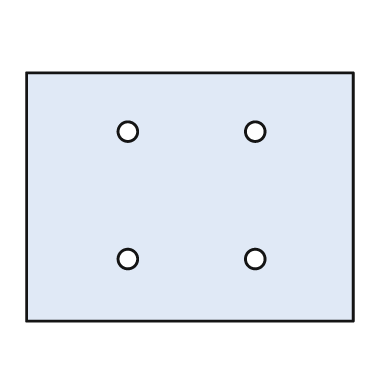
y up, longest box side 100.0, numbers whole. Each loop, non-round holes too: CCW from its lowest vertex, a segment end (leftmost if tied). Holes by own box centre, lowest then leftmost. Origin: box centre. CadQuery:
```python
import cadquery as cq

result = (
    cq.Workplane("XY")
    .moveTo(-50.0, -38.0)
    .lineTo(50.0, -38.0)
    .lineTo(50.0, 38.0)
    .lineTo(-50.0, 38.0)
    .close()
    .moveTo(-19.0, -19.0)
    .circle(3.0)
    .moveTo(20.0, -19.0)
    .circle(3.0)
    .moveTo(-19.0, 20.0)
    .circle(3.0)
    .moveTo(20.0, 20.0)
    .circle(3.0)
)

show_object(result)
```